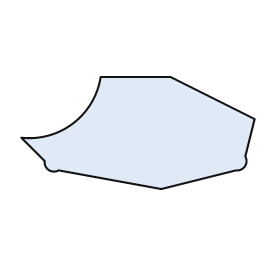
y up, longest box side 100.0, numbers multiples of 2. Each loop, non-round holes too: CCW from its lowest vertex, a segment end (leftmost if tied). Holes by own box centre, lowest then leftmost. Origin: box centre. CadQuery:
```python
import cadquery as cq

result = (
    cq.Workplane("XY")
    .moveTo(10.0, -24.0)
    .lineTo(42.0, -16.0)
    .threePointArc((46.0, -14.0), (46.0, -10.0))
    .lineTo(50.0, 6.0)
    .lineTo(14.0, 24.0)
    .lineTo(-16.0, 24.0)
    .threePointArc((-28.0, 4.0), (-50.0, -2.0))
    .lineTo(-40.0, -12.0)
    .threePointArc((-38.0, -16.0), (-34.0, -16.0))
    .close()
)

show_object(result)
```